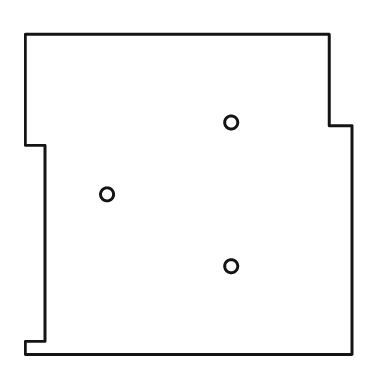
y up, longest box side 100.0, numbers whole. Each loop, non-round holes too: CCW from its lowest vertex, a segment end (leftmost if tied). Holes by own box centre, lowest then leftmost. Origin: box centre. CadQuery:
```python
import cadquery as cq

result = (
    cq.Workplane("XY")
    .moveTo(-50.0, -49.0)
    .lineTo(50.0, -49.0)
    .lineTo(50.0, 21.0)
    .lineTo(43.0, 21.0)
    .lineTo(43.0, 49.0)
    .lineTo(-50.0, 49.0)
    .lineTo(-50.0, 15.0)
    .lineTo(-44.0, 15.0)
    .lineTo(-44.0, -45.0)
    .lineTo(-50.0, -45.0)
    .close()
    .moveTo(13.0, -22.0)
    .circle(2.0)
    .moveTo(-25.0, 0.0)
    .circle(2.0)
    .moveTo(13.0, 22.0)
    .circle(2.0)
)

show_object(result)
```